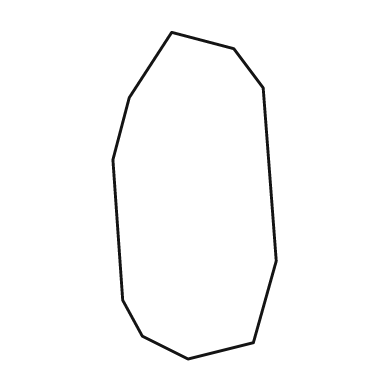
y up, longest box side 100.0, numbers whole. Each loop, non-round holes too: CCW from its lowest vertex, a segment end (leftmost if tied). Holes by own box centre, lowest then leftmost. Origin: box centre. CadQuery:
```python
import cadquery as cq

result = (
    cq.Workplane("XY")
    .moveTo(-2.0, -50.0)
    .lineTo(18.0, -45.0)
    .lineTo(25.0, -20.0)
    .lineTo(21.0, 33.0)
    .lineTo(12.0, 45.0)
    .lineTo(-7.0, 50.0)
    .lineTo(-20.0, 30.0)
    .lineTo(-25.0, 11.0)
    .lineTo(-22.0, -32.0)
    .lineTo(-16.0, -43.0)
    .close()
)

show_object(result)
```